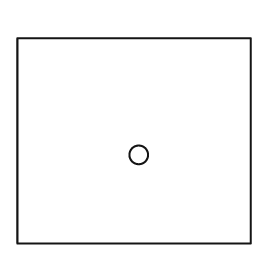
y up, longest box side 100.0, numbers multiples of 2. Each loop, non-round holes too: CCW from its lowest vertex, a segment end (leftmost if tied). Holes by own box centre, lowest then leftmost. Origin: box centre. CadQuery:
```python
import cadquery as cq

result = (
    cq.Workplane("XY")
    .moveTo(-50.0, -44.0)
    .lineTo(50.0, -44.0)
    .lineTo(50.0, 44.0)
    .lineTo(-50.0, 44.0)
    .close()
    .moveTo(2.0, -6.0)
    .circle(4.0)
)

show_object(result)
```